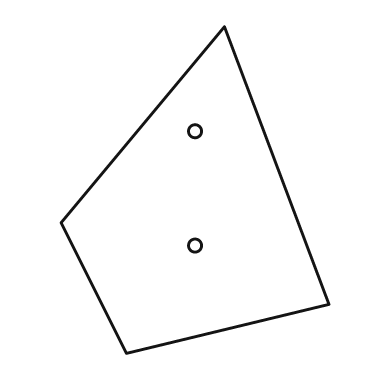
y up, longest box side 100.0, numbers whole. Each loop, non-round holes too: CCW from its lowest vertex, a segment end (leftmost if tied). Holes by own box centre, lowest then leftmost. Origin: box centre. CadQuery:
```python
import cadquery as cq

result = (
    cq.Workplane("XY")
    .moveTo(-21.0, -50.0)
    .lineTo(41.0, -35.0)
    .lineTo(9.0, 50.0)
    .lineTo(-41.0, -10.0)
    .close()
    .moveTo(0.0, -17.0)
    .circle(2.0)
    .moveTo(0.0, 18.0)
    .circle(2.0)
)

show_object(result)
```